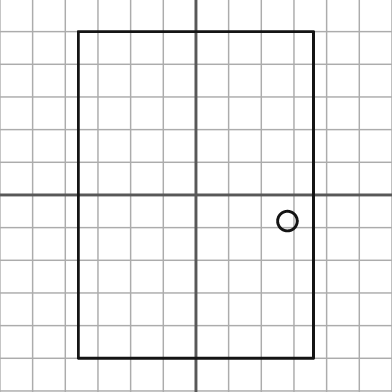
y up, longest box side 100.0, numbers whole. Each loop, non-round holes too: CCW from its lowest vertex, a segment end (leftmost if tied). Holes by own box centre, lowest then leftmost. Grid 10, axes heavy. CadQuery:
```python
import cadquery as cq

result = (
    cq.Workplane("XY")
    .moveTo(-36.0, -50.0)
    .lineTo(36.0, -50.0)
    .lineTo(36.0, 50.0)
    .lineTo(-36.0, 50.0)
    .close()
    .moveTo(28.0, -8.0)
    .circle(3.0)
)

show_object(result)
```